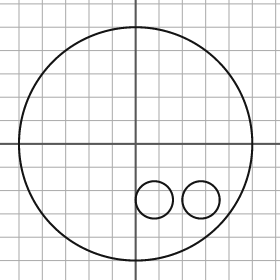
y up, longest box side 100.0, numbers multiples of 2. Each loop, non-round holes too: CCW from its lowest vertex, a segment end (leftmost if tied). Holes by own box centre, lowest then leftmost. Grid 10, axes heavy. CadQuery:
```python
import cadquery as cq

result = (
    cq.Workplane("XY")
    .moveTo(0.0, 0.0)
    .circle(50.0)
    .moveTo(8.0, -24.0)
    .circle(8.0)
    .moveTo(28.0, -24.0)
    .circle(8.0)
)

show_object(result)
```